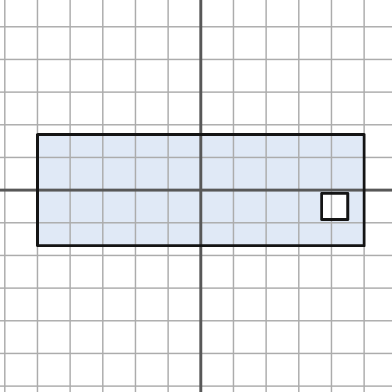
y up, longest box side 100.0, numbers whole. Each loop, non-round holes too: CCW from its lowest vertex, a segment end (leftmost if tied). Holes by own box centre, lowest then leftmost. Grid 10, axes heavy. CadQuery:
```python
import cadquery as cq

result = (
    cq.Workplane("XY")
    .moveTo(-50.0, -17.0)
    .lineTo(50.0, -17.0)
    .lineTo(50.0, 17.0)
    .lineTo(-50.0, 17.0)
    .close()
    .moveTo(37.0, -9.0)
    .lineTo(45.0, -9.0)
    .lineTo(45.0, -1.0)
    .lineTo(37.0, -1.0)
    .close()
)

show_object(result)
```